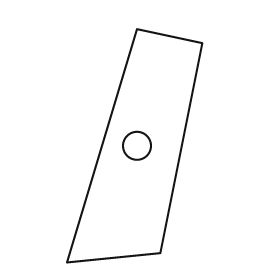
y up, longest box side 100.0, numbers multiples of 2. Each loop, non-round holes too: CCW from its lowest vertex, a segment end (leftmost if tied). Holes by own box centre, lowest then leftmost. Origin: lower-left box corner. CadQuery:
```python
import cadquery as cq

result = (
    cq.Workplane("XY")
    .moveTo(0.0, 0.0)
    .lineTo(40.0, 4.0)
    .lineTo(58.0, 94.0)
    .lineTo(30.0, 100.0)
    .close()
    .moveTo(30.0, 50.0)
    .circle(6.0)
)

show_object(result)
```